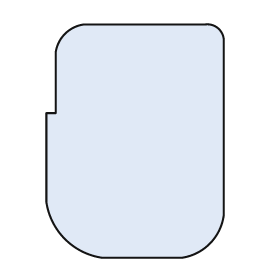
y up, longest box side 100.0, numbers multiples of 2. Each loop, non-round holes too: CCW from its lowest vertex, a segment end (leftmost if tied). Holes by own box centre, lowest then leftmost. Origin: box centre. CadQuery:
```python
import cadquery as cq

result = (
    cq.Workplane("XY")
    .moveTo(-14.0, -50.0)
    .lineTo(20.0, -50.0)
    .threePointArc((32.0, -44.0), (38.0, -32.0))
    .lineTo(38.0, 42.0)
    .threePointArc((36.0, 48.0), (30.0, 50.0))
    .lineTo(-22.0, 50.0)
    .threePointArc((-30.0, 46.0), (-34.0, 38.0))
    .lineTo(-34.0, 12.0)
    .lineTo(-38.0, 12.0)
    .lineTo(-38.0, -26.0)
    .threePointArc((-30.0, -42.0), (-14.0, -50.0))
    .close()
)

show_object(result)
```